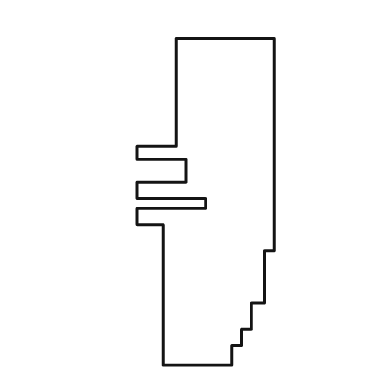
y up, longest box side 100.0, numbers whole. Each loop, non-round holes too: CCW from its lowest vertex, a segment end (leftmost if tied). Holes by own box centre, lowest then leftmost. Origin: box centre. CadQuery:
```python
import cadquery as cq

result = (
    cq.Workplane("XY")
    .moveTo(-13.0, -50.0)
    .lineTo(8.0, -50.0)
    .lineTo(8.0, -44.0)
    .lineTo(11.0, -44.0)
    .lineTo(11.0, -39.0)
    .lineTo(14.0, -39.0)
    .lineTo(14.0, -31.0)
    .lineTo(18.0, -31.0)
    .lineTo(18.0, -15.0)
    .lineTo(21.0, -15.0)
    .lineTo(21.0, 50.0)
    .lineTo(-9.0, 50.0)
    .lineTo(-9.0, 17.0)
    .lineTo(-21.0, 17.0)
    .lineTo(-21.0, 13.0)
    .lineTo(-6.0, 13.0)
    .lineTo(-6.0, 6.0)
    .lineTo(-21.0, 6.0)
    .lineTo(-21.0, 1.0)
    .lineTo(0.0, 1.0)
    .lineTo(0.0, -2.0)
    .lineTo(-21.0, -2.0)
    .lineTo(-21.0, -7.0)
    .lineTo(-13.0, -7.0)
    .close()
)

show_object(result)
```